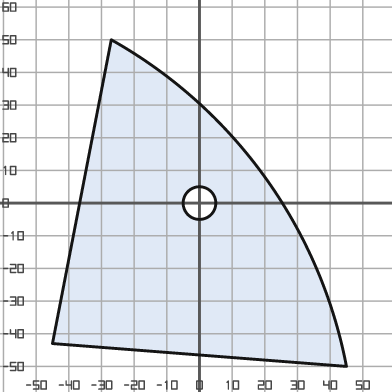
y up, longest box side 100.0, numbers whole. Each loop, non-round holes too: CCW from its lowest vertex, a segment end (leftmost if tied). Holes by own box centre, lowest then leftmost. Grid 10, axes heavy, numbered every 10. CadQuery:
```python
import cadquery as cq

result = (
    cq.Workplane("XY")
    .moveTo(45.0, -50.0)
    .threePointArc((20.0, 8.0), (-27.0, 50.0))
    .lineTo(-45.0, -43.0)
    .close()
    .moveTo(0.0, 0.0)
    .circle(5.0)
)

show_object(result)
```